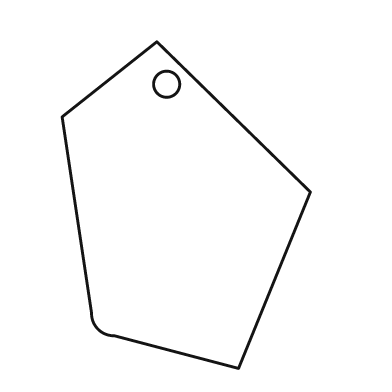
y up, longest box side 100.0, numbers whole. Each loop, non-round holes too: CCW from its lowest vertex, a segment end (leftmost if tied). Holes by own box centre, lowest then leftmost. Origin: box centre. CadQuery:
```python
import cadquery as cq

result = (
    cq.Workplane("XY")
    .moveTo(16.0, -50.0)
    .lineTo(38.0, 4.0)
    .lineTo(-9.0, 50.0)
    .lineTo(-38.0, 27.0)
    .lineTo(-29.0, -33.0)
    .threePointArc((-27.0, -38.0), (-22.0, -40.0))
    .close()
    .moveTo(-6.0, 37.0)
    .circle(4.0)
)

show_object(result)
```